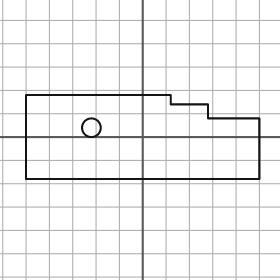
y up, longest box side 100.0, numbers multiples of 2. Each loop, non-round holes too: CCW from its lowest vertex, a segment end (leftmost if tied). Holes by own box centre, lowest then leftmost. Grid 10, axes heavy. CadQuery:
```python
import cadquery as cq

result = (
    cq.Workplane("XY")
    .moveTo(-50.0, -18.0)
    .lineTo(50.0, -18.0)
    .lineTo(50.0, 8.0)
    .lineTo(28.0, 8.0)
    .lineTo(28.0, 14.0)
    .lineTo(12.0, 14.0)
    .lineTo(12.0, 18.0)
    .lineTo(-50.0, 18.0)
    .close()
    .moveTo(-22.0, 4.0)
    .circle(4.0)
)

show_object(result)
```